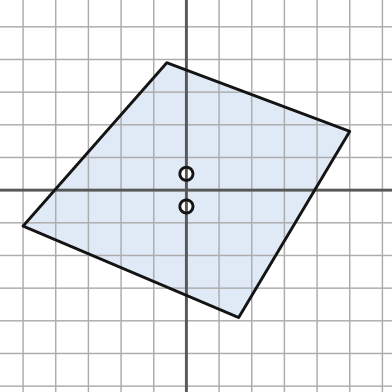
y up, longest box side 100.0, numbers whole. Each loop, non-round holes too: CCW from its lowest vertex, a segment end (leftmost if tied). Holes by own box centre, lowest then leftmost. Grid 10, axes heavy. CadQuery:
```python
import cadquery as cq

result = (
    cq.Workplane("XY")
    .moveTo(16.0, -39.0)
    .lineTo(50.0, 18.0)
    .lineTo(-6.0, 39.0)
    .lineTo(-50.0, -11.0)
    .close()
    .moveTo(0.0, -5.0)
    .circle(2.0)
    .moveTo(0.0, 5.0)
    .circle(2.0)
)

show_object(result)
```